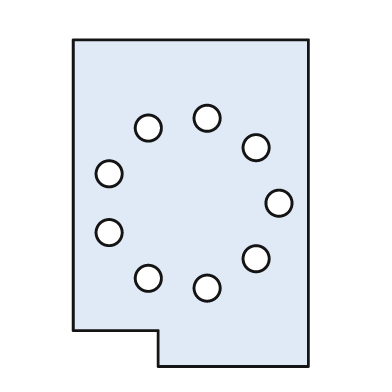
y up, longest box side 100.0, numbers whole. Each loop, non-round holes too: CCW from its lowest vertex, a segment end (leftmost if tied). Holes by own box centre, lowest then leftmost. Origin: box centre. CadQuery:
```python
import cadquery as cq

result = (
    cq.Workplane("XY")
    .moveTo(-10.0, -50.0)
    .lineTo(36.0, -50.0)
    .lineTo(36.0, 50.0)
    .lineTo(-36.0, 50.0)
    .lineTo(-36.0, -39.0)
    .lineTo(-10.0, -39.0)
    .close()
    .moveTo(5.0, -26.0)
    .circle(4.0)
    .moveTo(-13.0, -23.0)
    .circle(4.0)
    .moveTo(20.0, -17.0)
    .circle(4.0)
    .moveTo(-25.0, -9.0)
    .circle(4.0)
    .moveTo(27.0, 0.0)
    .circle(4.0)
    .moveTo(-25.0, 9.0)
    .circle(4.0)
    .moveTo(20.0, 17.0)
    .circle(4.0)
    .moveTo(-13.0, 23.0)
    .circle(4.0)
    .moveTo(5.0, 26.0)
    .circle(4.0)
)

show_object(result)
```